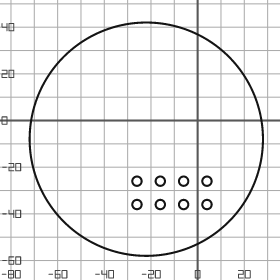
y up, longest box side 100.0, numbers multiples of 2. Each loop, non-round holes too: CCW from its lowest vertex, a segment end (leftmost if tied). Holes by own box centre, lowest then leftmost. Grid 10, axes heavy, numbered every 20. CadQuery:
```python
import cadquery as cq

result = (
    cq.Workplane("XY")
    .moveTo(-22.0, -8.0)
    .circle(50.0)
    .moveTo(-26.0, -36.0)
    .circle(2.0)
    .moveTo(-16.0, -36.0)
    .circle(2.0)
    .moveTo(-6.0, -36.0)
    .circle(2.0)
    .moveTo(4.0, -36.0)
    .circle(2.0)
    .moveTo(-26.0, -26.0)
    .circle(2.0)
    .moveTo(-16.0, -26.0)
    .circle(2.0)
    .moveTo(-6.0, -26.0)
    .circle(2.0)
    .moveTo(4.0, -26.0)
    .circle(2.0)
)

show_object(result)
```